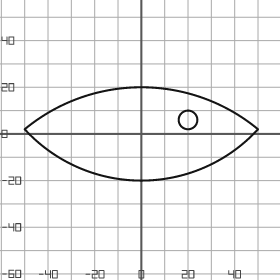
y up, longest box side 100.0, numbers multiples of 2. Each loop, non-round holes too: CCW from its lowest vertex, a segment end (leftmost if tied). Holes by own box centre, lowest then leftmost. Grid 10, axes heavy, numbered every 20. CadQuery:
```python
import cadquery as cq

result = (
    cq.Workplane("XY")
    .moveTo(-50.0, 2.0)
    .threePointArc((0.0, -20.0), (50.0, 2.0))
    .threePointArc((0.0, 20.0), (-50.0, 2.0))
    .close()
    .moveTo(20.0, 6.0)
    .circle(4.0)
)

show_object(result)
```